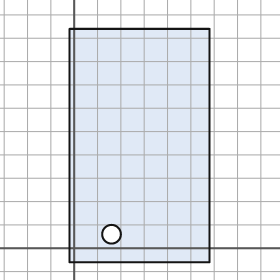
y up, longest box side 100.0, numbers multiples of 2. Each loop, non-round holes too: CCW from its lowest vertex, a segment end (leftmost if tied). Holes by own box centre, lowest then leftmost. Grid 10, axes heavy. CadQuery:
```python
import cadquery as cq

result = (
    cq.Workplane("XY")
    .moveTo(-2.0, -6.0)
    .lineTo(58.0, -6.0)
    .lineTo(58.0, 94.0)
    .lineTo(-2.0, 94.0)
    .close()
    .moveTo(16.0, 6.0)
    .circle(4.0)
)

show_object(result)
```